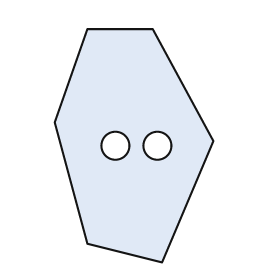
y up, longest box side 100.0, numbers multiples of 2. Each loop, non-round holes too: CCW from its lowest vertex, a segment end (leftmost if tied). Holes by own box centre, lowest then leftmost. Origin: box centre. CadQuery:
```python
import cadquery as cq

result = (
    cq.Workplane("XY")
    .moveTo(12.0, -50.0)
    .lineTo(34.0, 2.0)
    .lineTo(8.0, 50.0)
    .lineTo(-20.0, 50.0)
    .lineTo(-34.0, 10.0)
    .lineTo(-20.0, -42.0)
    .close()
    .moveTo(-8.0, 0.0)
    .circle(6.0)
    .moveTo(10.0, 0.0)
    .circle(6.0)
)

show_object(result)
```